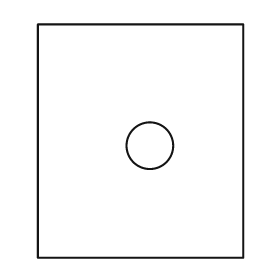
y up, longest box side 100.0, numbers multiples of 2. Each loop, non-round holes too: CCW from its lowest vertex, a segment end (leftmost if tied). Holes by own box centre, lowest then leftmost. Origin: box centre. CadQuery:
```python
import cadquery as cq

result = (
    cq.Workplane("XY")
    .moveTo(-44.0, -50.0)
    .lineTo(44.0, -50.0)
    .lineTo(44.0, 50.0)
    .lineTo(-44.0, 50.0)
    .close()
    .moveTo(4.0, -2.0)
    .circle(10.0)
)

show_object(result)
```